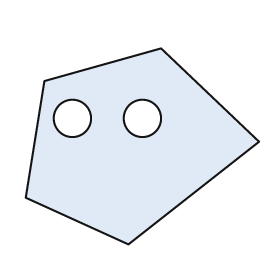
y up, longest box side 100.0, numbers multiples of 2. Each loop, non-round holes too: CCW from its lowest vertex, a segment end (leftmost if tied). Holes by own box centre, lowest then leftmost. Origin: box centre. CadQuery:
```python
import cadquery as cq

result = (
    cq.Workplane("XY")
    .moveTo(-6.0, -42.0)
    .lineTo(50.0, 2.0)
    .lineTo(8.0, 42.0)
    .lineTo(-42.0, 28.0)
    .lineTo(-50.0, -22.0)
    .close()
    .moveTo(-30.0, 12.0)
    .circle(8.0)
    .moveTo(0.0, 12.0)
    .circle(8.0)
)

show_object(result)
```